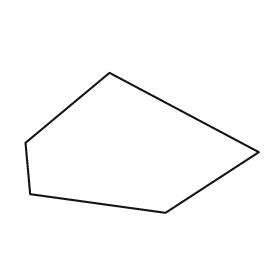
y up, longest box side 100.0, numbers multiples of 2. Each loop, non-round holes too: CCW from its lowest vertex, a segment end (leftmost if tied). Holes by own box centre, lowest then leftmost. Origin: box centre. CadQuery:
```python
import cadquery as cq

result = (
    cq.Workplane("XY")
    .moveTo(10.0, -30.0)
    .lineTo(50.0, -4.0)
    .lineTo(-14.0, 30.0)
    .lineTo(-50.0, 0.0)
    .lineTo(-48.0, -22.0)
    .close()
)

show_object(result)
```